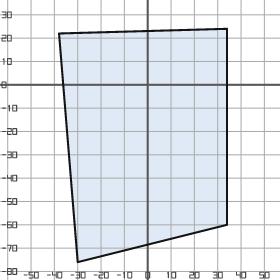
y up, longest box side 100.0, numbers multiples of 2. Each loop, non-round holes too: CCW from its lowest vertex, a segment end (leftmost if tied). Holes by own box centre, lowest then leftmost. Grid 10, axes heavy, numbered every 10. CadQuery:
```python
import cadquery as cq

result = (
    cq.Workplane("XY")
    .moveTo(-30.0, -76.0)
    .lineTo(34.0, -60.0)
    .lineTo(34.0, 24.0)
    .lineTo(-38.0, 22.0)
    .close()
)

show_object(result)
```